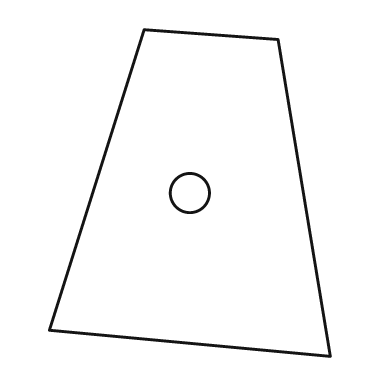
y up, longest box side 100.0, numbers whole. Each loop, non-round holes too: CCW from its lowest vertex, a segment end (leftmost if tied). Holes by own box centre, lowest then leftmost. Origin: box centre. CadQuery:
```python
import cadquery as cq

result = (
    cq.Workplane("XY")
    .moveTo(43.0, -50.0)
    .lineTo(27.0, 47.0)
    .lineTo(-14.0, 50.0)
    .lineTo(-43.0, -42.0)
    .close()
    .moveTo(0.0, 0.0)
    .circle(6.0)
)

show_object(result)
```